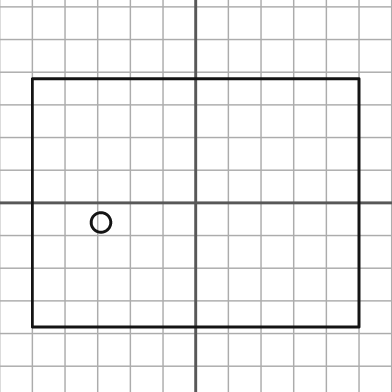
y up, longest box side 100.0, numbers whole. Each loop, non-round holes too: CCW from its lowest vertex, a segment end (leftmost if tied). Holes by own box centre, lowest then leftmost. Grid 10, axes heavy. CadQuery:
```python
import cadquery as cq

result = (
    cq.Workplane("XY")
    .moveTo(-50.0, -38.0)
    .lineTo(50.0, -38.0)
    .lineTo(50.0, 38.0)
    .lineTo(-50.0, 38.0)
    .close()
    .moveTo(-29.0, -6.0)
    .circle(3.0)
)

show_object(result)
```